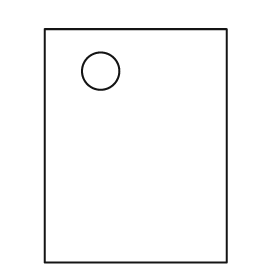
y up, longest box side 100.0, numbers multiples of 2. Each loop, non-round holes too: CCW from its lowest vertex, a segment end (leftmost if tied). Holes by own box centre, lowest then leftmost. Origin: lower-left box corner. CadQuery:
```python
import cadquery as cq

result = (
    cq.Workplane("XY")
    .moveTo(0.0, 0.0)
    .lineTo(78.0, 0.0)
    .lineTo(78.0, 100.0)
    .lineTo(0.0, 100.0)
    .close()
    .moveTo(24.0, 82.0)
    .circle(8.0)
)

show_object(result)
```